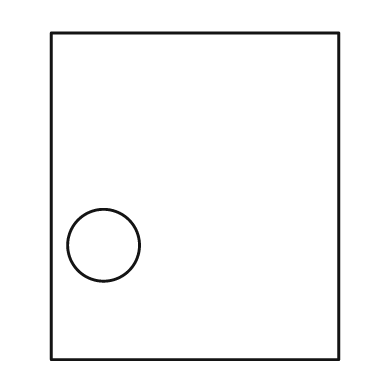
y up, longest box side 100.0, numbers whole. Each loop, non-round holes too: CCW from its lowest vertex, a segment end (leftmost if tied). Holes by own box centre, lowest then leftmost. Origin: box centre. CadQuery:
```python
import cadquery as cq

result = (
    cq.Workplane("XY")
    .moveTo(-44.0, -50.0)
    .lineTo(44.0, -50.0)
    .lineTo(44.0, 50.0)
    .lineTo(-44.0, 50.0)
    .close()
    .moveTo(-28.0, -15.0)
    .circle(11.0)
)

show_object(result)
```